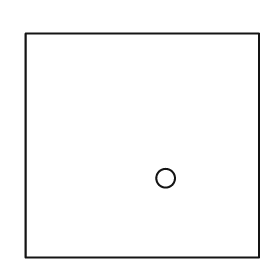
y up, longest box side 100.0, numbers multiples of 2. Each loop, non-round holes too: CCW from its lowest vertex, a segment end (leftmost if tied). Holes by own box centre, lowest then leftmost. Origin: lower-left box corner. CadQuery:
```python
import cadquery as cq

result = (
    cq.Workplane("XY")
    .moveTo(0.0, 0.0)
    .lineTo(100.0, 0.0)
    .lineTo(100.0, 96.0)
    .lineTo(0.0, 96.0)
    .close()
    .moveTo(60.0, 34.0)
    .circle(4.0)
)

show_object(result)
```